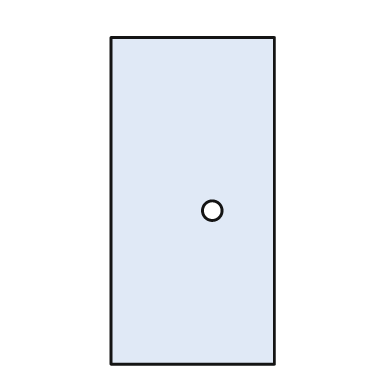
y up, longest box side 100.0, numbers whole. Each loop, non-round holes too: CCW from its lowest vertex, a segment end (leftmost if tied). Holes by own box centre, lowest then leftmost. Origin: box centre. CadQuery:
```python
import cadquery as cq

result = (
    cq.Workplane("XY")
    .moveTo(-25.0, -50.0)
    .lineTo(25.0, -50.0)
    .lineTo(25.0, 50.0)
    .lineTo(-25.0, 50.0)
    .close()
    .moveTo(6.0, -3.0)
    .circle(3.0)
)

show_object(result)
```